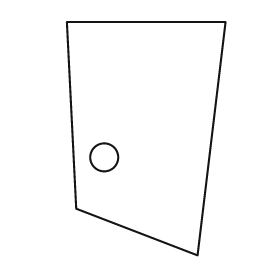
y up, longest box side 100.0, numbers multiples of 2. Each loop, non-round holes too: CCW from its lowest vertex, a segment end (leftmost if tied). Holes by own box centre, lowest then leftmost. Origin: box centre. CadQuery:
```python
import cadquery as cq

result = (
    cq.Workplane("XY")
    .moveTo(22.0, -50.0)
    .lineTo(34.0, 50.0)
    .lineTo(-34.0, 50.0)
    .lineTo(-30.0, -30.0)
    .close()
    .moveTo(-18.0, -8.0)
    .circle(6.0)
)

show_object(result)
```